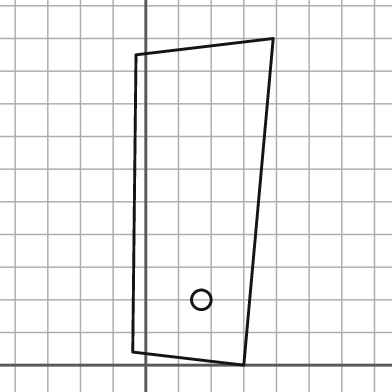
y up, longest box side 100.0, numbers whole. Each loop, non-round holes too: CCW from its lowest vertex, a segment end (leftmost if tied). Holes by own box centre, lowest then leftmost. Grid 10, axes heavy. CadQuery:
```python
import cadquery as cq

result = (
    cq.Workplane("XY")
    .moveTo(30.0, 0.0)
    .lineTo(39.0, 100.0)
    .lineTo(-3.0, 95.0)
    .lineTo(-4.0, 4.0)
    .close()
    .moveTo(17.0, 20.0)
    .circle(3.0)
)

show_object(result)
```